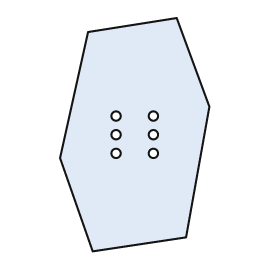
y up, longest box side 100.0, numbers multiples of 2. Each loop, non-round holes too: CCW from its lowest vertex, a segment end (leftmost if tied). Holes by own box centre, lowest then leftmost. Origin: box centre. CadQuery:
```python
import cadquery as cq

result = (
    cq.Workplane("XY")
    .moveTo(-18.0, -50.0)
    .lineTo(22.0, -44.0)
    .lineTo(32.0, 12.0)
    .lineTo(18.0, 50.0)
    .lineTo(-20.0, 44.0)
    .lineTo(-32.0, -10.0)
    .close()
    .moveTo(-8.0, -8.0)
    .circle(2.0)
    .moveTo(8.0, -8.0)
    .circle(2.0)
    .moveTo(-8.0, 0.0)
    .circle(2.0)
    .moveTo(8.0, 0.0)
    .circle(2.0)
    .moveTo(-8.0, 8.0)
    .circle(2.0)
    .moveTo(8.0, 8.0)
    .circle(2.0)
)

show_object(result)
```